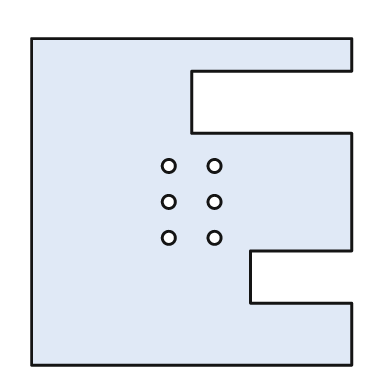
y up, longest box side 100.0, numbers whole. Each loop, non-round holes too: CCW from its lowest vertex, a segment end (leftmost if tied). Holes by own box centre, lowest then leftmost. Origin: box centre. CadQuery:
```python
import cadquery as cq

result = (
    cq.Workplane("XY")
    .moveTo(-49.0, -50.0)
    .lineTo(49.0, -50.0)
    .lineTo(49.0, -31.0)
    .lineTo(18.0, -31.0)
    .lineTo(18.0, -15.0)
    .lineTo(49.0, -15.0)
    .lineTo(49.0, 21.0)
    .lineTo(0.0, 21.0)
    .lineTo(0.0, 40.0)
    .lineTo(49.0, 40.0)
    .lineTo(49.0, 50.0)
    .lineTo(-49.0, 50.0)
    .close()
    .moveTo(-7.0, -11.0)
    .circle(2.0)
    .moveTo(7.0, -11.0)
    .circle(2.0)
    .moveTo(-7.0, 0.0)
    .circle(2.0)
    .moveTo(7.0, 0.0)
    .circle(2.0)
    .moveTo(-7.0, 11.0)
    .circle(2.0)
    .moveTo(7.0, 11.0)
    .circle(2.0)
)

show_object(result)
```